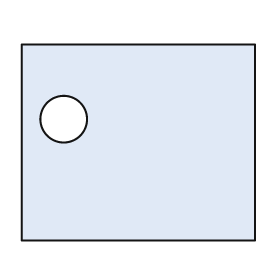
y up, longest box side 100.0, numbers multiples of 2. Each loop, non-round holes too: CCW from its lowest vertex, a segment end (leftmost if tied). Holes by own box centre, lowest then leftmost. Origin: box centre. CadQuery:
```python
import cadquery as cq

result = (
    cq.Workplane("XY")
    .moveTo(-50.0, -42.0)
    .lineTo(50.0, -42.0)
    .lineTo(50.0, 42.0)
    .lineTo(-50.0, 42.0)
    .close()
    .moveTo(-32.0, 10.0)
    .circle(10.0)
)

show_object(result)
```